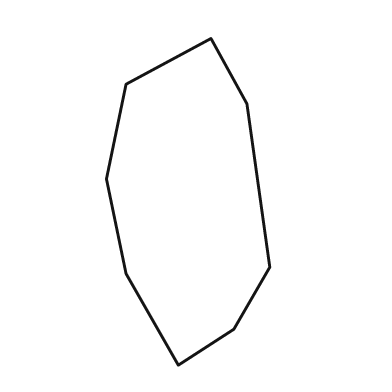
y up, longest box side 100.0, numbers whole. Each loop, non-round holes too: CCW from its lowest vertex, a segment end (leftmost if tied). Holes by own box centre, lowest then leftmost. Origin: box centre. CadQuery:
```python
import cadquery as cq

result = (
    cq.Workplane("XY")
    .moveTo(-3.0, -50.0)
    .lineTo(14.0, -39.0)
    .lineTo(25.0, -20.0)
    .lineTo(18.0, 30.0)
    .lineTo(7.0, 50.0)
    .lineTo(-19.0, 36.0)
    .lineTo(-25.0, 7.0)
    .lineTo(-19.0, -22.0)
    .close()
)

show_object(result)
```